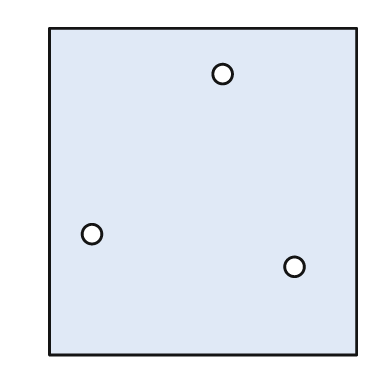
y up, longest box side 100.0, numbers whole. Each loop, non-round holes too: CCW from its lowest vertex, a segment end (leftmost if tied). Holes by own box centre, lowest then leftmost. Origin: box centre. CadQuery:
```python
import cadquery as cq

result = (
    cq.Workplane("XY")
    .moveTo(-47.0, -50.0)
    .lineTo(47.0, -50.0)
    .lineTo(47.0, 50.0)
    .lineTo(-47.0, 50.0)
    .close()
    .moveTo(28.0, -23.0)
    .circle(3.0)
    .moveTo(-34.0, -13.0)
    .circle(3.0)
    .moveTo(6.0, 36.0)
    .circle(3.0)
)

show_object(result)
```